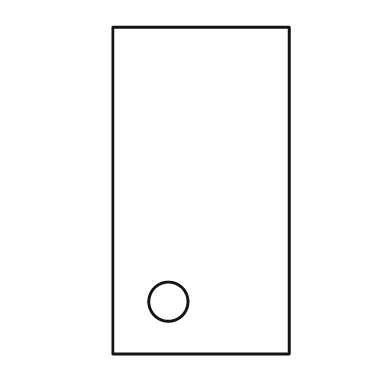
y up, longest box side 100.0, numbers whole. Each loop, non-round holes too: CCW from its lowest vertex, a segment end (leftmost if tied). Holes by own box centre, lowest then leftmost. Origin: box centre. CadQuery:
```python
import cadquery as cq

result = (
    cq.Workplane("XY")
    .moveTo(-27.0, -50.0)
    .lineTo(27.0, -50.0)
    .lineTo(27.0, 50.0)
    .lineTo(-27.0, 50.0)
    .close()
    .moveTo(-10.0, -34.0)
    .circle(6.0)
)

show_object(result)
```